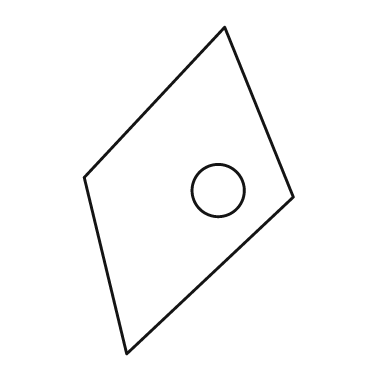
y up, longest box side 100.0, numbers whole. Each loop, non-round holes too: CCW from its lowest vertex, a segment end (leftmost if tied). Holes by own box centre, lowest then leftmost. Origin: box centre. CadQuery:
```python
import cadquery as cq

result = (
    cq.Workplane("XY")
    .moveTo(-19.0, -50.0)
    .lineTo(32.0, -2.0)
    .lineTo(11.0, 50.0)
    .lineTo(-32.0, 4.0)
    .close()
    .moveTo(9.0, 0.0)
    .circle(8.0)
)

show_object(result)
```